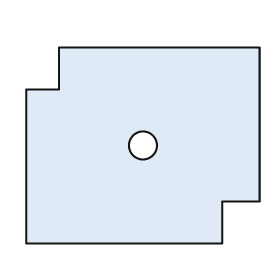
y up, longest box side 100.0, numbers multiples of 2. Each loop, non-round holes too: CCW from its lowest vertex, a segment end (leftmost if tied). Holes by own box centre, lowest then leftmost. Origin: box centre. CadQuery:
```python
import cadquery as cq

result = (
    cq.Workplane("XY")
    .moveTo(-50.0, -42.0)
    .lineTo(34.0, -42.0)
    .lineTo(34.0, -24.0)
    .lineTo(50.0, -24.0)
    .lineTo(50.0, 42.0)
    .lineTo(-36.0, 42.0)
    .lineTo(-36.0, 24.0)
    .lineTo(-50.0, 24.0)
    .close()
    .moveTo(0.0, 0.0)
    .circle(6.0)
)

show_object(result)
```